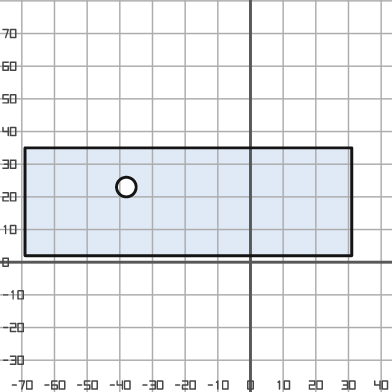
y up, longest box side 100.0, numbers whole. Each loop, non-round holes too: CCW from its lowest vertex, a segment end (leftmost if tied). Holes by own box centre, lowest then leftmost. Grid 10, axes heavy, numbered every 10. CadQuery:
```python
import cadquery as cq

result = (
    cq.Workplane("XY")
    .moveTo(-69.0, 2.0)
    .lineTo(31.0, 2.0)
    .lineTo(31.0, 35.0)
    .lineTo(-69.0, 35.0)
    .close()
    .moveTo(-38.0, 23.0)
    .circle(3.0)
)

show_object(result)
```